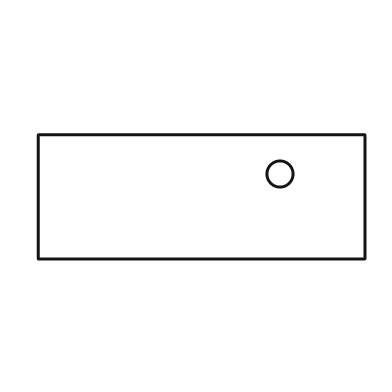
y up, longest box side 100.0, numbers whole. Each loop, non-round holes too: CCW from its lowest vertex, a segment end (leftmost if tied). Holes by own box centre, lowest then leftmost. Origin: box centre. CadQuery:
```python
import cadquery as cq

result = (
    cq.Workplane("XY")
    .moveTo(-50.0, -19.0)
    .lineTo(50.0, -19.0)
    .lineTo(50.0, 19.0)
    .lineTo(-50.0, 19.0)
    .close()
    .moveTo(24.0, 7.0)
    .circle(4.0)
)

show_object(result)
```